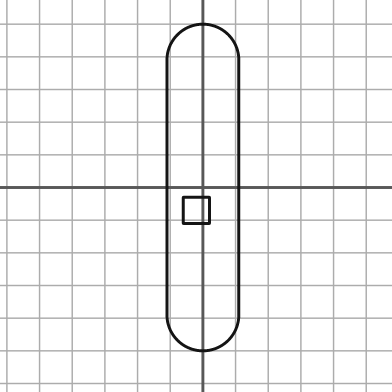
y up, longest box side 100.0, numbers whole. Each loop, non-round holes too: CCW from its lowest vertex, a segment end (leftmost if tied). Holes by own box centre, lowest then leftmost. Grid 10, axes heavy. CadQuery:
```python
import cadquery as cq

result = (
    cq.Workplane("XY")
    .moveTo(-11.0, -39.0)
    .threePointArc((0.0, -50.0), (11.0, -39.0))
    .lineTo(11.0, 39.0)
    .threePointArc((0.0, 50.0), (-11.0, 39.0))
    .close()
    .moveTo(-6.0, -11.0)
    .lineTo(2.0, -11.0)
    .lineTo(2.0, -3.0)
    .lineTo(-6.0, -3.0)
    .close()
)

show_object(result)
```